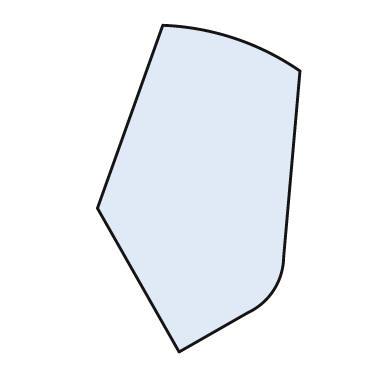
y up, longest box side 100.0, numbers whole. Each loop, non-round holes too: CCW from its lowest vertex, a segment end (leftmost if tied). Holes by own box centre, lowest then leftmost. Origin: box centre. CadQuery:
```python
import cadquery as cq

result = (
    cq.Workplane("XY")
    .moveTo(-6.0, -50.0)
    .lineTo(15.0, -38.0)
    .threePointArc((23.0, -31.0), (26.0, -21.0))
    .lineTo(31.0, 36.0)
    .threePointArc((11.0, 46.0), (-11.0, 50.0))
    .lineTo(-31.0, -6.0)
    .close()
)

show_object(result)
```